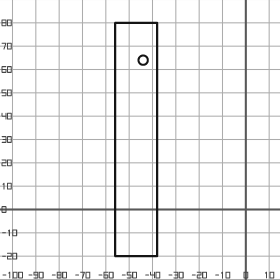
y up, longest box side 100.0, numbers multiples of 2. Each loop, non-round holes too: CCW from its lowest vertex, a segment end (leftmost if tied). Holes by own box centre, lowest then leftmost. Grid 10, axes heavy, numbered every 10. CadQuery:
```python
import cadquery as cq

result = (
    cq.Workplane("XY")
    .moveTo(-56.0, -20.0)
    .lineTo(-38.0, -20.0)
    .lineTo(-38.0, 80.0)
    .lineTo(-56.0, 80.0)
    .close()
    .moveTo(-44.0, 64.0)
    .circle(2.0)
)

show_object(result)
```